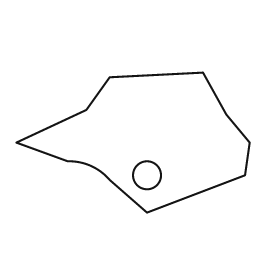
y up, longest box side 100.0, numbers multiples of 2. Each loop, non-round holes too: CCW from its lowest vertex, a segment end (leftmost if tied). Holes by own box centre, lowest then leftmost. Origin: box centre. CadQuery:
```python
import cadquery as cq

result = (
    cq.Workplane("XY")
    .moveTo(6.0, -30.0)
    .lineTo(48.0, -14.0)
    .lineTo(50.0, 0.0)
    .lineTo(40.0, 12.0)
    .lineTo(30.0, 30.0)
    .lineTo(-10.0, 28.0)
    .lineTo(-20.0, 14.0)
    .lineTo(-50.0, 0.0)
    .lineTo(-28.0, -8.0)
    .threePointArc((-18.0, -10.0), (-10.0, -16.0))
    .close()
    .moveTo(6.0, -14.0)
    .circle(6.0)
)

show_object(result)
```